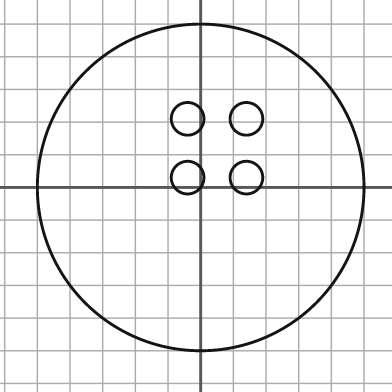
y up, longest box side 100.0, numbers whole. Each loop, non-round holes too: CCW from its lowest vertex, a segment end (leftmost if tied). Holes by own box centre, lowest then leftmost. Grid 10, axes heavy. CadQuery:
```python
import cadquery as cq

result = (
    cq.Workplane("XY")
    .moveTo(0.0, 0.0)
    .circle(50.0)
    .moveTo(-4.0, 3.0)
    .circle(5.0)
    .moveTo(14.0, 3.0)
    .circle(5.0)
    .moveTo(-4.0, 21.0)
    .circle(5.0)
    .moveTo(14.0, 21.0)
    .circle(5.0)
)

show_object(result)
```